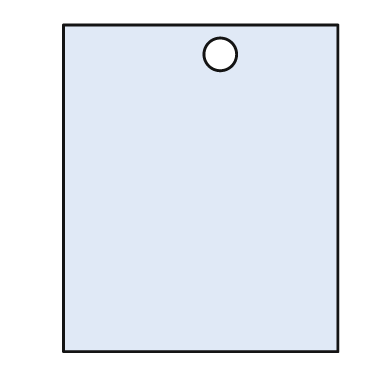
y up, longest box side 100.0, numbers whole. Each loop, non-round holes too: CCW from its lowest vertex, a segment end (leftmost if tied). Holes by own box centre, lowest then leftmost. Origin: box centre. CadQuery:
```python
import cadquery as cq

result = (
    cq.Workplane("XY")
    .moveTo(-42.0, -50.0)
    .lineTo(42.0, -50.0)
    .lineTo(42.0, 50.0)
    .lineTo(-42.0, 50.0)
    .close()
    .moveTo(6.0, 41.0)
    .circle(5.0)
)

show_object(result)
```